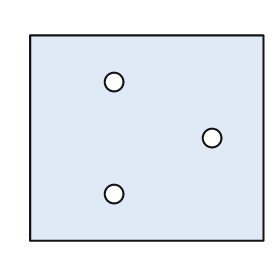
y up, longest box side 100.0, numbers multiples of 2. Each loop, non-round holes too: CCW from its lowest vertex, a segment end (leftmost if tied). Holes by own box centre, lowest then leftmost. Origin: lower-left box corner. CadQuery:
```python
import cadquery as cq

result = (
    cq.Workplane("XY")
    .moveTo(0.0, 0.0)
    .lineTo(100.0, 0.0)
    .lineTo(100.0, 88.0)
    .lineTo(0.0, 88.0)
    .close()
    .moveTo(36.0, 20.0)
    .circle(4.0)
    .moveTo(78.0, 44.0)
    .circle(4.0)
    .moveTo(36.0, 68.0)
    .circle(4.0)
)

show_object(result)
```